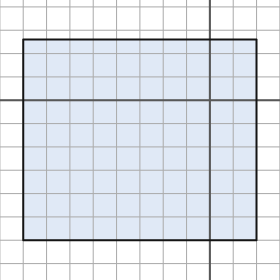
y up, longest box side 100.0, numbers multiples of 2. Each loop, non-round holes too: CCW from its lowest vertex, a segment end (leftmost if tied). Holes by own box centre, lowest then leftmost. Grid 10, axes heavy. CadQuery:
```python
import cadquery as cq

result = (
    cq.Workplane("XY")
    .moveTo(-80.0, -60.0)
    .lineTo(20.0, -60.0)
    .lineTo(20.0, 26.0)
    .lineTo(-80.0, 26.0)
    .close()
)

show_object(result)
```